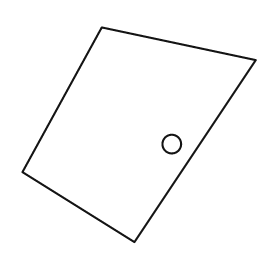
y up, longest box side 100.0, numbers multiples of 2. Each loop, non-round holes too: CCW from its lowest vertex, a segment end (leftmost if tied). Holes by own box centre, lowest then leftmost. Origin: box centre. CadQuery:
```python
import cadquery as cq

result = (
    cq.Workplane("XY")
    .moveTo(-2.0, -46.0)
    .lineTo(50.0, 32.0)
    .lineTo(-16.0, 46.0)
    .lineTo(-50.0, -16.0)
    .close()
    .moveTo(14.0, -4.0)
    .circle(4.0)
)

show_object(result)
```